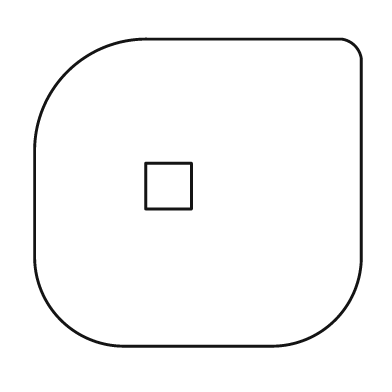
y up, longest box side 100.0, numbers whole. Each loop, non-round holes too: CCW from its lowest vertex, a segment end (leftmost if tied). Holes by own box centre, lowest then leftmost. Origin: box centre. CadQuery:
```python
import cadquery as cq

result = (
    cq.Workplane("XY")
    .moveTo(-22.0, -47.0)
    .lineTo(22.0, -47.0)
    .threePointArc((42.0, -39.0), (50.0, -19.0))
    .lineTo(50.0, 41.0)
    .threePointArc((48.0, 45.0), (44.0, 47.0))
    .lineTo(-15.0, 47.0)
    .threePointArc((-40.0, 37.0), (-50.0, 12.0))
    .lineTo(-50.0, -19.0)
    .threePointArc((-42.0, -39.0), (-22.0, -47.0))
    .close()
    .moveTo(-16.0, -5.0)
    .lineTo(-2.0, -5.0)
    .lineTo(-2.0, 9.0)
    .lineTo(-16.0, 9.0)
    .close()
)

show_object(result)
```